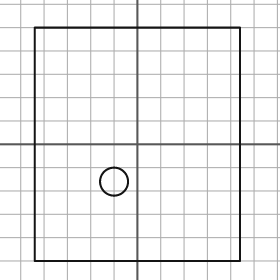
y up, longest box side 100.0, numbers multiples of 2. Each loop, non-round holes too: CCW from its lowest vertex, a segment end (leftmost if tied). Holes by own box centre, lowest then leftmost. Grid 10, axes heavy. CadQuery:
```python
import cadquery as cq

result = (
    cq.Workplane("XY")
    .moveTo(-44.0, -50.0)
    .lineTo(44.0, -50.0)
    .lineTo(44.0, 50.0)
    .lineTo(-44.0, 50.0)
    .close()
    .moveTo(-10.0, -16.0)
    .circle(6.0)
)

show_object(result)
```